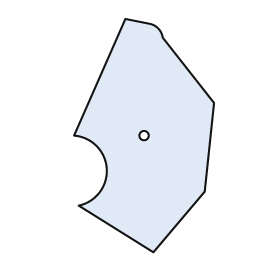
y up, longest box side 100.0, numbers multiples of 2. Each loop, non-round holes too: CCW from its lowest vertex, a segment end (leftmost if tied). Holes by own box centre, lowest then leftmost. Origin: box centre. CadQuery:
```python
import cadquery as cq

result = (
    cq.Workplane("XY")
    .moveTo(4.0, -50.0)
    .lineTo(26.0, -24.0)
    .lineTo(30.0, 14.0)
    .lineTo(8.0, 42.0)
    .threePointArc((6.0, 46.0), (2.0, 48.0))
    .lineTo(-8.0, 50.0)
    .lineTo(-30.0, 0.0)
    .threePointArc((-16.0, -14.0), (-28.0, -30.0))
    .close()
    .moveTo(0.0, 0.0)
    .circle(2.0)
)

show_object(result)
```